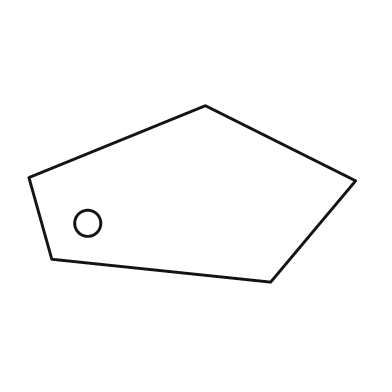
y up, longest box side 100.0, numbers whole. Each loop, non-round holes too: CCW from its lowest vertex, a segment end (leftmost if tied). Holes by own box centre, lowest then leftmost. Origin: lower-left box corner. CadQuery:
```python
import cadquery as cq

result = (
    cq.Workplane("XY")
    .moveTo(74.0, 0.0)
    .lineTo(100.0, 31.0)
    .lineTo(54.0, 54.0)
    .lineTo(0.0, 32.0)
    .lineTo(7.0, 7.0)
    .close()
    .moveTo(18.0, 18.0)
    .circle(4.0)
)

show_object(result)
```